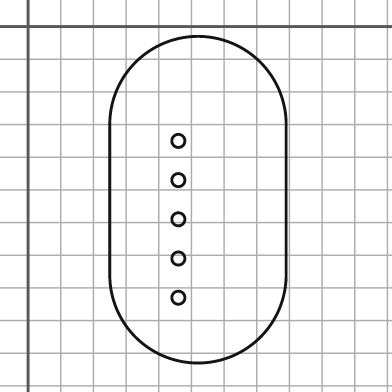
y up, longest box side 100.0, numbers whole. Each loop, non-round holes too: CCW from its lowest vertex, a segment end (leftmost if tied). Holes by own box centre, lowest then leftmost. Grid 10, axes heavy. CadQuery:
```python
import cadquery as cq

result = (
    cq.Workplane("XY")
    .moveTo(25.0, -76.0)
    .threePointArc((52.0, -103.0), (79.0, -76.0))
    .lineTo(79.0, -30.0)
    .threePointArc((52.0, -3.0), (25.0, -30.0))
    .close()
    .moveTo(46.0, -83.0)
    .circle(2.0)
    .moveTo(46.0, -71.0)
    .circle(2.0)
    .moveTo(46.0, -59.0)
    .circle(2.0)
    .moveTo(46.0, -47.0)
    .circle(2.0)
    .moveTo(46.0, -35.0)
    .circle(2.0)
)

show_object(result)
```